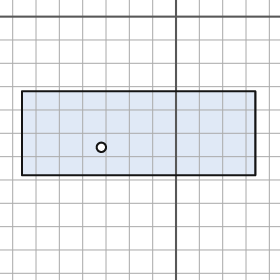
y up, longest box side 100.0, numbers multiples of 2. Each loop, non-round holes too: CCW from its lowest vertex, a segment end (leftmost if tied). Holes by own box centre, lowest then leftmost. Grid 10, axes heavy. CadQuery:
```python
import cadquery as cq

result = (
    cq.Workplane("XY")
    .moveTo(-66.0, -68.0)
    .lineTo(34.0, -68.0)
    .lineTo(34.0, -32.0)
    .lineTo(-66.0, -32.0)
    .close()
    .moveTo(-32.0, -56.0)
    .circle(2.0)
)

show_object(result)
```